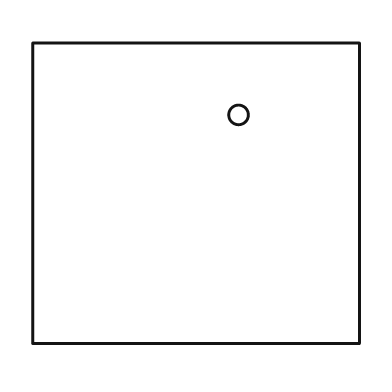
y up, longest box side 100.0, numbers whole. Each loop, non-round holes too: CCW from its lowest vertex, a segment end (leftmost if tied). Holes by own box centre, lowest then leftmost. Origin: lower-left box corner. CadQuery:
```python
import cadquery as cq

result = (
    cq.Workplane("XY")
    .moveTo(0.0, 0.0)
    .lineTo(100.0, 0.0)
    .lineTo(100.0, 92.0)
    .lineTo(0.0, 92.0)
    .close()
    .moveTo(63.0, 70.0)
    .circle(3.0)
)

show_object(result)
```